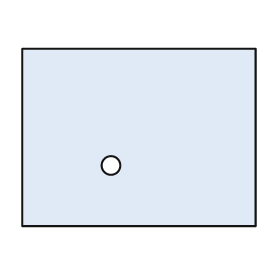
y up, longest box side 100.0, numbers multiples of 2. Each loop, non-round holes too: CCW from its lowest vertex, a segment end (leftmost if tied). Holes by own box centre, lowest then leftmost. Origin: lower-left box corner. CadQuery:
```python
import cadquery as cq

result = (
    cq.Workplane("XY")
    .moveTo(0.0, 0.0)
    .lineTo(100.0, 0.0)
    .lineTo(100.0, 76.0)
    .lineTo(0.0, 76.0)
    .close()
    .moveTo(38.0, 26.0)
    .circle(4.0)
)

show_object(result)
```